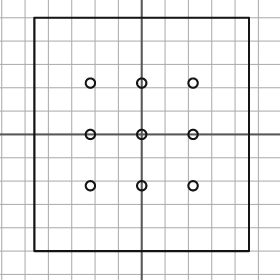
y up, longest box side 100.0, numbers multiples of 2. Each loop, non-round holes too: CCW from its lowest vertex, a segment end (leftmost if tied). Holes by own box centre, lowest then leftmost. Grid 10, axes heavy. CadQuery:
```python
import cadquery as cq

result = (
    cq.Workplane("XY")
    .moveTo(-46.0, -50.0)
    .lineTo(46.0, -50.0)
    .lineTo(46.0, 50.0)
    .lineTo(-46.0, 50.0)
    .close()
    .moveTo(-22.0, -22.0)
    .circle(2.0)
    .moveTo(0.0, -22.0)
    .circle(2.0)
    .moveTo(22.0, -22.0)
    .circle(2.0)
    .moveTo(-22.0, 0.0)
    .circle(2.0)
    .moveTo(0.0, 0.0)
    .circle(2.0)
    .moveTo(22.0, 0.0)
    .circle(2.0)
    .moveTo(-22.0, 22.0)
    .circle(2.0)
    .moveTo(0.0, 22.0)
    .circle(2.0)
    .moveTo(22.0, 22.0)
    .circle(2.0)
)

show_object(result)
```